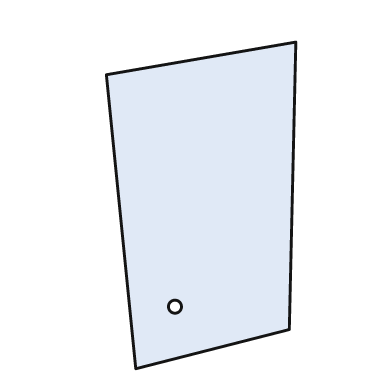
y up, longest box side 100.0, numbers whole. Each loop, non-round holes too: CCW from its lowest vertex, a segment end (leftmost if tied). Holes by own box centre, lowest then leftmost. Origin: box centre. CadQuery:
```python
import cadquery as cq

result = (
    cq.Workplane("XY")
    .moveTo(-20.0, -50.0)
    .lineTo(27.0, -38.0)
    .lineTo(29.0, 50.0)
    .lineTo(-29.0, 40.0)
    .close()
    .moveTo(-8.0, -31.0)
    .circle(2.0)
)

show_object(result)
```